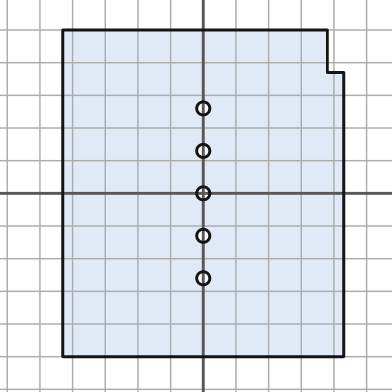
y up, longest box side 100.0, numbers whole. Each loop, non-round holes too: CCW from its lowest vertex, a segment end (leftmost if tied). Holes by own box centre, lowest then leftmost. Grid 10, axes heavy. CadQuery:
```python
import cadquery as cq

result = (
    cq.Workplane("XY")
    .moveTo(-43.0, -50.0)
    .lineTo(43.0, -50.0)
    .lineTo(43.0, 37.0)
    .lineTo(38.0, 37.0)
    .lineTo(38.0, 50.0)
    .lineTo(-43.0, 50.0)
    .close()
    .moveTo(0.0, -26.0)
    .circle(2.0)
    .moveTo(0.0, -13.0)
    .circle(2.0)
    .moveTo(0.0, 0.0)
    .circle(2.0)
    .moveTo(0.0, 13.0)
    .circle(2.0)
    .moveTo(0.0, 26.0)
    .circle(2.0)
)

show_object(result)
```